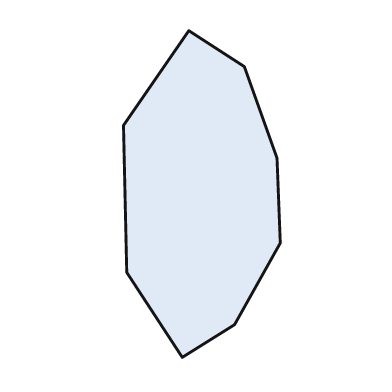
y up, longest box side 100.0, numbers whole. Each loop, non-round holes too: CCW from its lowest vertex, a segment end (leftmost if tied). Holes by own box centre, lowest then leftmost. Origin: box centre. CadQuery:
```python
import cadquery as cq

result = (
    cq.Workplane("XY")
    .moveTo(-6.0, -50.0)
    .lineTo(10.0, -40.0)
    .lineTo(24.0, -15.0)
    .lineTo(23.0, 11.0)
    .lineTo(13.0, 39.0)
    .lineTo(-4.0, 50.0)
    .lineTo(-24.0, 21.0)
    .lineTo(-23.0, -24.0)
    .close()
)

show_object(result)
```